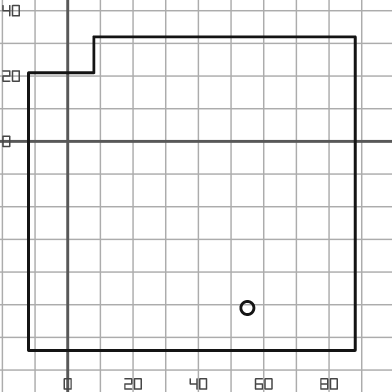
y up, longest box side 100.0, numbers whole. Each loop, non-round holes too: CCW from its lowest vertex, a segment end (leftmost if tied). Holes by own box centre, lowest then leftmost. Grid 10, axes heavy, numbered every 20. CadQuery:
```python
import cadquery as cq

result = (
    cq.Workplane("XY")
    .moveTo(-12.0, -64.0)
    .lineTo(88.0, -64.0)
    .lineTo(88.0, 32.0)
    .lineTo(8.0, 32.0)
    .lineTo(8.0, 21.0)
    .lineTo(-12.0, 21.0)
    .close()
    .moveTo(55.0, -51.0)
    .circle(2.0)
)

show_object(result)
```